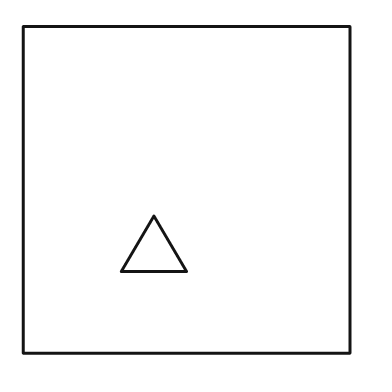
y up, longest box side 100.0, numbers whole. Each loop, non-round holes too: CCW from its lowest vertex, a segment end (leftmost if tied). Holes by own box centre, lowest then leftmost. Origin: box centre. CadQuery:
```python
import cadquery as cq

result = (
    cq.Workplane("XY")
    .moveTo(-50.0, -50.0)
    .lineTo(50.0, -50.0)
    .lineTo(50.0, 50.0)
    .lineTo(-50.0, 50.0)
    .close()
    .moveTo(-20.0, -25.0)
    .lineTo(0.0, -25.0)
    .lineTo(-10.0, -8.0)
    .close()
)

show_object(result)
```